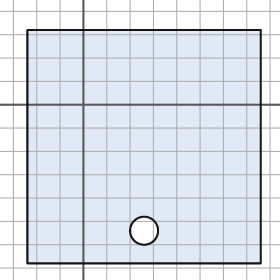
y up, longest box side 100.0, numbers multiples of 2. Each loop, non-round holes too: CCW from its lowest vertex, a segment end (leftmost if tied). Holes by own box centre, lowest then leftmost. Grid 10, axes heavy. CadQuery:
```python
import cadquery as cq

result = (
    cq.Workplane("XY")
    .moveTo(-24.0, -68.0)
    .lineTo(76.0, -68.0)
    .lineTo(76.0, 32.0)
    .lineTo(-24.0, 32.0)
    .close()
    .moveTo(26.0, -54.0)
    .circle(6.0)
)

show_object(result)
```